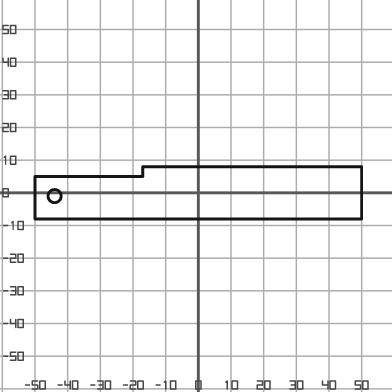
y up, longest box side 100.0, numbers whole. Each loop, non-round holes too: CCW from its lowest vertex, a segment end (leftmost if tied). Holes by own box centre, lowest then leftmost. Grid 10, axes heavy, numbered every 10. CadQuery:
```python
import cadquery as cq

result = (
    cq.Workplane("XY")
    .moveTo(-50.0, -8.0)
    .lineTo(50.0, -8.0)
    .lineTo(50.0, 8.0)
    .lineTo(-17.0, 8.0)
    .lineTo(-17.0, 5.0)
    .lineTo(-50.0, 5.0)
    .close()
    .moveTo(-44.0, -1.0)
    .circle(2.0)
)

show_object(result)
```